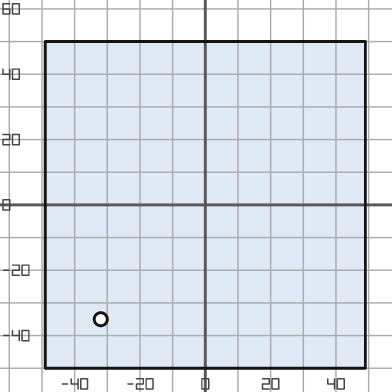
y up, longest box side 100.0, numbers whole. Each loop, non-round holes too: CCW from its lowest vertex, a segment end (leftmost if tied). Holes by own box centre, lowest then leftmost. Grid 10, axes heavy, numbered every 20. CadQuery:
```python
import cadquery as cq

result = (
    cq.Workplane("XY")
    .moveTo(-49.0, -50.0)
    .lineTo(49.0, -50.0)
    .lineTo(49.0, 50.0)
    .lineTo(-49.0, 50.0)
    .close()
    .moveTo(-32.0, -35.0)
    .circle(2.0)
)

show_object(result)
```